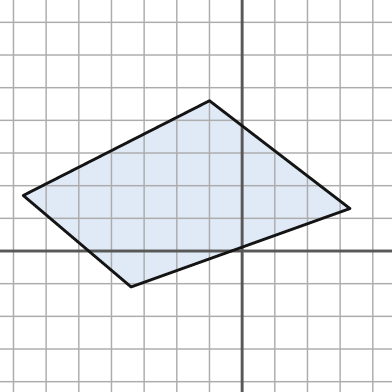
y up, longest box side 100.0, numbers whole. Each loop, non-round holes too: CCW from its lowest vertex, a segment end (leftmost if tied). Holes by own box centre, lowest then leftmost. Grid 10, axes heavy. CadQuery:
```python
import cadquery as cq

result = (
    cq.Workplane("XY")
    .moveTo(-34.0, -11.0)
    .lineTo(33.0, 13.0)
    .lineTo(-10.0, 46.0)
    .lineTo(-67.0, 17.0)
    .close()
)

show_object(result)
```